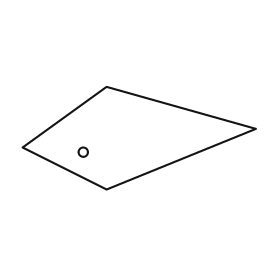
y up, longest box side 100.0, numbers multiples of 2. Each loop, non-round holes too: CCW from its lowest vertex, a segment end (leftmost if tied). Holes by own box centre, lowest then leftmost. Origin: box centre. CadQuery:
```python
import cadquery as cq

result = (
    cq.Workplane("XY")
    .moveTo(-14.0, -22.0)
    .lineTo(50.0, 4.0)
    .lineTo(-14.0, 22.0)
    .lineTo(-50.0, -4.0)
    .close()
    .moveTo(-24.0, -6.0)
    .circle(2.0)
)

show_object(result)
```